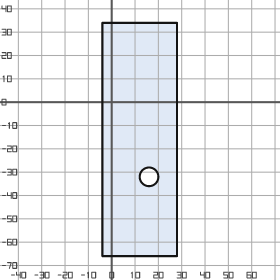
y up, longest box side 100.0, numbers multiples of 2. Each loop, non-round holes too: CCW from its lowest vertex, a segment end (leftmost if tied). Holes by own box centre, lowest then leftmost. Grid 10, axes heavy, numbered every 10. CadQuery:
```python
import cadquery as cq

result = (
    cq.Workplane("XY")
    .moveTo(-4.0, -66.0)
    .lineTo(28.0, -66.0)
    .lineTo(28.0, 34.0)
    .lineTo(-4.0, 34.0)
    .close()
    .moveTo(16.0, -32.0)
    .circle(4.0)
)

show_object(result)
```